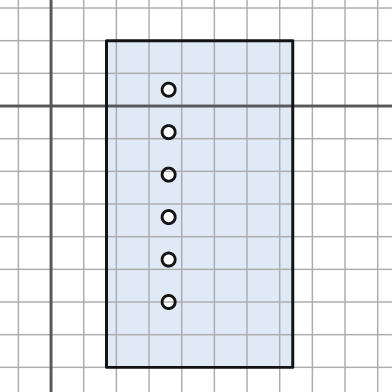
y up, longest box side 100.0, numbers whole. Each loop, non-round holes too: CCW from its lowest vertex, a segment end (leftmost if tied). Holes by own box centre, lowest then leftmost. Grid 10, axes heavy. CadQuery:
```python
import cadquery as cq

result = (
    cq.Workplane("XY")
    .moveTo(17.0, -80.0)
    .lineTo(74.0, -80.0)
    .lineTo(74.0, 20.0)
    .lineTo(17.0, 20.0)
    .close()
    .moveTo(36.0, -60.0)
    .circle(2.0)
    .moveTo(36.0, -47.0)
    .circle(2.0)
    .moveTo(36.0, -34.0)
    .circle(2.0)
    .moveTo(36.0, -21.0)
    .circle(2.0)
    .moveTo(36.0, -8.0)
    .circle(2.0)
    .moveTo(36.0, 5.0)
    .circle(2.0)
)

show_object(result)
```